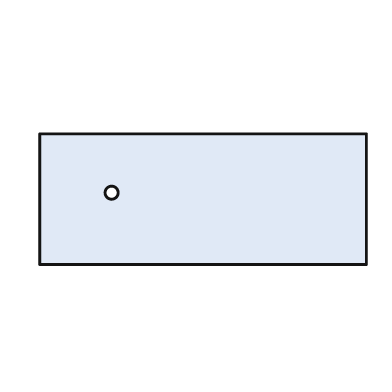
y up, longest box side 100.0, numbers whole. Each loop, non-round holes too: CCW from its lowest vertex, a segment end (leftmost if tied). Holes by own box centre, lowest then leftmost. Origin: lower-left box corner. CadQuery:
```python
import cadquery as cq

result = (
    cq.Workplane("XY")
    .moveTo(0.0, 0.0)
    .lineTo(100.0, 0.0)
    .lineTo(100.0, 40.0)
    .lineTo(0.0, 40.0)
    .close()
    .moveTo(22.0, 22.0)
    .circle(2.0)
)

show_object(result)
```